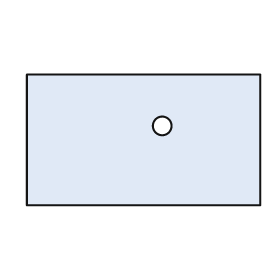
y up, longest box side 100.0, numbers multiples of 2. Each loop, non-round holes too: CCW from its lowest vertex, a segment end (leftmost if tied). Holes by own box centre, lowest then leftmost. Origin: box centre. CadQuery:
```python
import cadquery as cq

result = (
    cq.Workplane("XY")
    .moveTo(-50.0, -28.0)
    .lineTo(50.0, -28.0)
    .lineTo(50.0, 28.0)
    .lineTo(-50.0, 28.0)
    .close()
    .moveTo(8.0, 6.0)
    .circle(4.0)
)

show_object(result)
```